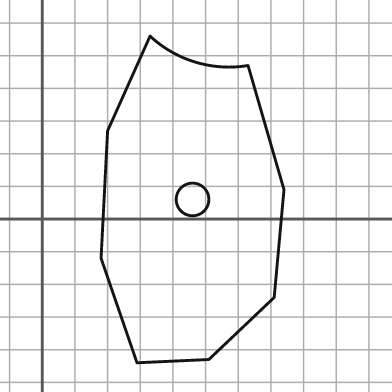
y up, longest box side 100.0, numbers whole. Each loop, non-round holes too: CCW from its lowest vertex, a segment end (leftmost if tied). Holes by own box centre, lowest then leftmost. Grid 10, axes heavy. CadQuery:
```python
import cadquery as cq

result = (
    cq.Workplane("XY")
    .moveTo(29.0, -44.0)
    .lineTo(51.0, -43.0)
    .lineTo(71.0, -24.0)
    .lineTo(74.0, 9.0)
    .lineTo(63.0, 47.0)
    .threePointArc((47.0, 48.0), (33.0, 56.0))
    .lineTo(20.0, 27.0)
    .lineTo(18.0, -12.0)
    .close()
    .moveTo(46.0, 6.0)
    .circle(5.0)
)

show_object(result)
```